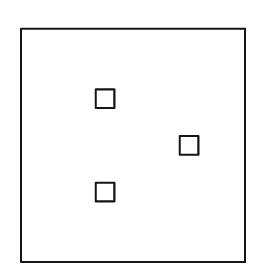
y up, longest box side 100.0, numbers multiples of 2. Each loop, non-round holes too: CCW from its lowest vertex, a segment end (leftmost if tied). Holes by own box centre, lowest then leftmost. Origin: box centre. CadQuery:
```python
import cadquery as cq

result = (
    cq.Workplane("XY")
    .moveTo(-48.0, -50.0)
    .lineTo(48.0, -50.0)
    .lineTo(48.0, 50.0)
    .lineTo(-48.0, 50.0)
    .close()
    .moveTo(-16.0, -24.0)
    .lineTo(-8.0, -24.0)
    .lineTo(-8.0, -16.0)
    .lineTo(-16.0, -16.0)
    .close()
    .moveTo(20.0, -4.0)
    .lineTo(28.0, -4.0)
    .lineTo(28.0, 4.0)
    .lineTo(20.0, 4.0)
    .close()
    .moveTo(-16.0, 16.0)
    .lineTo(-8.0, 16.0)
    .lineTo(-8.0, 24.0)
    .lineTo(-16.0, 24.0)
    .close()
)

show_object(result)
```